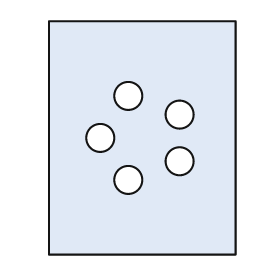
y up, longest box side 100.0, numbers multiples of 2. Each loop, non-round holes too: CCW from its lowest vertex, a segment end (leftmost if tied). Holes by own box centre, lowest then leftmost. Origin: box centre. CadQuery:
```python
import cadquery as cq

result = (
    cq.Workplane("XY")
    .moveTo(-40.0, -50.0)
    .lineTo(40.0, -50.0)
    .lineTo(40.0, 50.0)
    .lineTo(-40.0, 50.0)
    .close()
    .moveTo(-6.0, -18.0)
    .circle(6.0)
    .moveTo(16.0, -10.0)
    .circle(6.0)
    .moveTo(-18.0, 0.0)
    .circle(6.0)
    .moveTo(16.0, 10.0)
    .circle(6.0)
    .moveTo(-6.0, 18.0)
    .circle(6.0)
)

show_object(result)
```